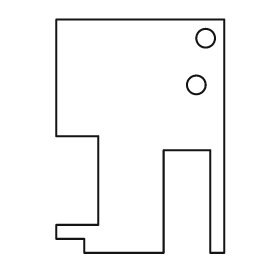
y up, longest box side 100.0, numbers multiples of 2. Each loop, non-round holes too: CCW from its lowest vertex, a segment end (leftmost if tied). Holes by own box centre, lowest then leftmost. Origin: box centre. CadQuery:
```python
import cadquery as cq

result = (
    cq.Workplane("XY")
    .moveTo(-24.0, -50.0)
    .lineTo(10.0, -50.0)
    .lineTo(10.0, -6.0)
    .lineTo(30.0, -6.0)
    .lineTo(30.0, -50.0)
    .lineTo(36.0, -50.0)
    .lineTo(36.0, 50.0)
    .lineTo(-36.0, 50.0)
    .lineTo(-36.0, 0.0)
    .lineTo(-18.0, 0.0)
    .lineTo(-18.0, -38.0)
    .lineTo(-36.0, -38.0)
    .lineTo(-36.0, -44.0)
    .lineTo(-24.0, -44.0)
    .close()
    .moveTo(24.0, 22.0)
    .circle(4.0)
    .moveTo(28.0, 42.0)
    .circle(4.0)
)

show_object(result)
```